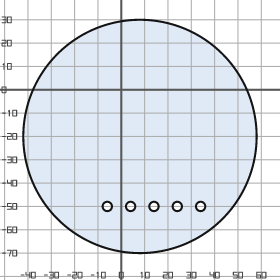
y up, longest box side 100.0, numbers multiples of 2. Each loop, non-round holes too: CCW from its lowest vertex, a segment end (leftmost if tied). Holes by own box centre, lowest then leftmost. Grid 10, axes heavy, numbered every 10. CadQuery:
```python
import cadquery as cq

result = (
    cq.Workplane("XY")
    .moveTo(8.0, -20.0)
    .circle(50.0)
    .moveTo(-6.0, -50.0)
    .circle(2.0)
    .moveTo(4.0, -50.0)
    .circle(2.0)
    .moveTo(14.0, -50.0)
    .circle(2.0)
    .moveTo(24.0, -50.0)
    .circle(2.0)
    .moveTo(34.0, -50.0)
    .circle(2.0)
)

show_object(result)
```